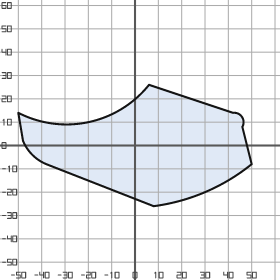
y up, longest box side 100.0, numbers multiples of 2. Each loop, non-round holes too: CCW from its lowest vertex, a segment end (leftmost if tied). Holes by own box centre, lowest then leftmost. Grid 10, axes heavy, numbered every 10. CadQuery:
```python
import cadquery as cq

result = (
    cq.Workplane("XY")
    .moveTo(8.0, -26.0)
    .threePointArc((30.0, -20.0), (50.0, -8.0))
    .lineTo(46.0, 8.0)
    .threePointArc((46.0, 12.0), (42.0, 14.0))
    .lineTo(6.0, 26.0)
    .threePointArc((-20.0, 10.0), (-50.0, 14.0))
    .lineTo(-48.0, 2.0)
    .threePointArc((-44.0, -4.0), (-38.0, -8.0))
    .close()
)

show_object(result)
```